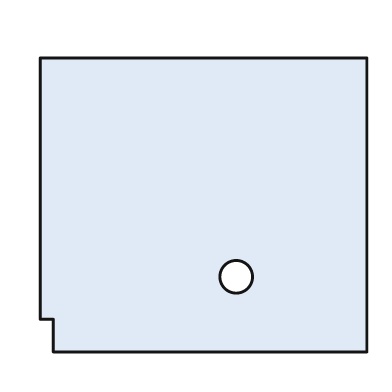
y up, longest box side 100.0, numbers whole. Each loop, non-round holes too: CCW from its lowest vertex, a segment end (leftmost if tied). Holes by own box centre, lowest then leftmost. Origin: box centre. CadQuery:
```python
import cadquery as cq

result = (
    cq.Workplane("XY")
    .moveTo(-46.0, -45.0)
    .lineTo(50.0, -45.0)
    .lineTo(50.0, 45.0)
    .lineTo(-50.0, 45.0)
    .lineTo(-50.0, -35.0)
    .lineTo(-46.0, -35.0)
    .close()
    .moveTo(10.0, -22.0)
    .circle(5.0)
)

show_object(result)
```